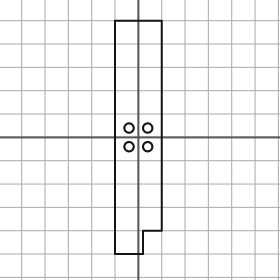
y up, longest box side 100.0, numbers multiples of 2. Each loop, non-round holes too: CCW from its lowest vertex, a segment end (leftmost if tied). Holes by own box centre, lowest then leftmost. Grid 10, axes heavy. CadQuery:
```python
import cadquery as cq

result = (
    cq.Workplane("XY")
    .moveTo(-10.0, -50.0)
    .lineTo(2.0, -50.0)
    .lineTo(2.0, -40.0)
    .lineTo(10.0, -40.0)
    .lineTo(10.0, 50.0)
    .lineTo(-10.0, 50.0)
    .close()
    .moveTo(-4.0, -4.0)
    .circle(2.0)
    .moveTo(4.0, -4.0)
    .circle(2.0)
    .moveTo(-4.0, 4.0)
    .circle(2.0)
    .moveTo(4.0, 4.0)
    .circle(2.0)
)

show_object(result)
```